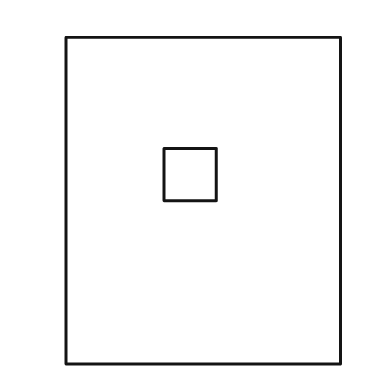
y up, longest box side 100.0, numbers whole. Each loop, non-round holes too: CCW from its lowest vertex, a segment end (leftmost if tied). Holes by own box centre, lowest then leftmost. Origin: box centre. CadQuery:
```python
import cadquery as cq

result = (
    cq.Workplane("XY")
    .moveTo(-42.0, -50.0)
    .lineTo(42.0, -50.0)
    .lineTo(42.0, 50.0)
    .lineTo(-42.0, 50.0)
    .close()
    .moveTo(-12.0, 0.0)
    .lineTo(4.0, 0.0)
    .lineTo(4.0, 16.0)
    .lineTo(-12.0, 16.0)
    .close()
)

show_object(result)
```